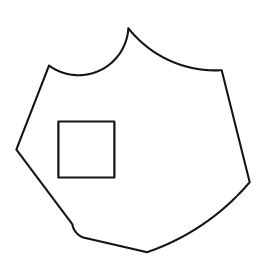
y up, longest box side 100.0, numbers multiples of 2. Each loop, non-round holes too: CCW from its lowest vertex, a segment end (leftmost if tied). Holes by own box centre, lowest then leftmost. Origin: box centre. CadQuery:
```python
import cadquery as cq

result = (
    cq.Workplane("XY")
    .moveTo(6.0, -48.0)
    .threePointArc((30.0, -36.0), (50.0, -18.0))
    .lineTo(38.0, 30.0)
    .threePointArc((16.0, 34.0), (-2.0, 48.0))
    .threePointArc((-14.0, 30.0), (-36.0, 32.0))
    .lineTo(-50.0, -4.0)
    .lineTo(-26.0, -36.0)
    .threePointArc((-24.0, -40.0), (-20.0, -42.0))
    .close()
    .moveTo(-32.0, -16.0)
    .lineTo(-8.0, -16.0)
    .lineTo(-8.0, 8.0)
    .lineTo(-32.0, 8.0)
    .close()
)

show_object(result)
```